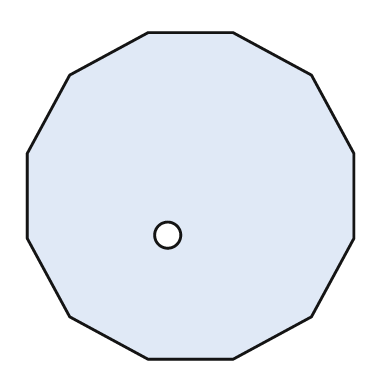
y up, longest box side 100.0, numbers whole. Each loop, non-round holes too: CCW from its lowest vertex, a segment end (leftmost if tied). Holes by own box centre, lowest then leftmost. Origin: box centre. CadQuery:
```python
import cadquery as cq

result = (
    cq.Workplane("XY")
    .moveTo(-13.0, -50.0)
    .lineTo(13.0, -50.0)
    .lineTo(37.0, -37.0)
    .lineTo(50.0, -13.0)
    .lineTo(50.0, 13.0)
    .lineTo(37.0, 37.0)
    .lineTo(13.0, 50.0)
    .lineTo(-13.0, 50.0)
    .lineTo(-37.0, 37.0)
    .lineTo(-50.0, 13.0)
    .lineTo(-50.0, -13.0)
    .lineTo(-37.0, -37.0)
    .close()
    .moveTo(-7.0, -12.0)
    .circle(4.0)
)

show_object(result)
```